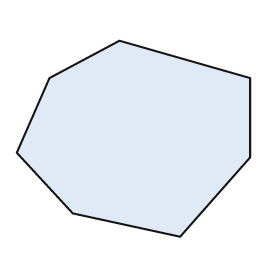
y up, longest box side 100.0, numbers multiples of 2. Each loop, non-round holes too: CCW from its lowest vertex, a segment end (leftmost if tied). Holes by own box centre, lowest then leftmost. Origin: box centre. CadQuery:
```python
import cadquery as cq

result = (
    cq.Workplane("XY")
    .moveTo(20.0, -42.0)
    .lineTo(50.0, -8.0)
    .lineTo(50.0, 26.0)
    .lineTo(-6.0, 42.0)
    .lineTo(-36.0, 26.0)
    .lineTo(-50.0, -6.0)
    .lineTo(-26.0, -32.0)
    .close()
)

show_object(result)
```